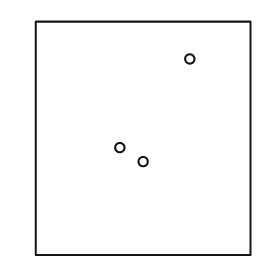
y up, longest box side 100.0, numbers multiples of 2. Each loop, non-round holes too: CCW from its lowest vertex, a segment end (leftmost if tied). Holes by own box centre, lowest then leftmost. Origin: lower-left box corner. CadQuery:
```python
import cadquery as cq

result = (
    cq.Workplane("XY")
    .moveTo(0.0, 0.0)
    .lineTo(92.0, 0.0)
    .lineTo(92.0, 100.0)
    .lineTo(0.0, 100.0)
    .close()
    .moveTo(46.0, 40.0)
    .circle(2.0)
    .moveTo(36.0, 46.0)
    .circle(2.0)
    .moveTo(66.0, 84.0)
    .circle(2.0)
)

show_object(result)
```